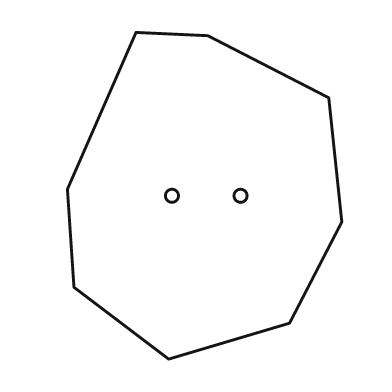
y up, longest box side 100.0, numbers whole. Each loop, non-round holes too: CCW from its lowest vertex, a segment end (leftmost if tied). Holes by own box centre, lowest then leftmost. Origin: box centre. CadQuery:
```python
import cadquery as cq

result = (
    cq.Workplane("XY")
    .moveTo(-11.0, -50.0)
    .lineTo(26.0, -39.0)
    .lineTo(42.0, -8.0)
    .lineTo(38.0, 30.0)
    .lineTo(1.0, 49.0)
    .lineTo(-21.0, 50.0)
    .lineTo(-42.0, 2.0)
    .lineTo(-40.0, -28.0)
    .close()
    .moveTo(-10.0, 0.0)
    .circle(2.0)
    .moveTo(11.0, 0.0)
    .circle(2.0)
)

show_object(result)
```